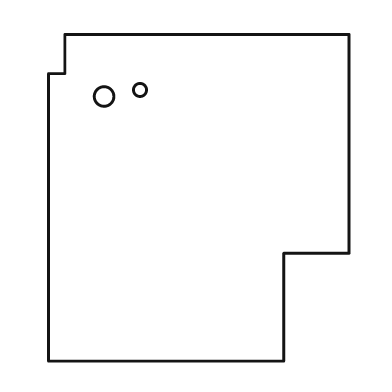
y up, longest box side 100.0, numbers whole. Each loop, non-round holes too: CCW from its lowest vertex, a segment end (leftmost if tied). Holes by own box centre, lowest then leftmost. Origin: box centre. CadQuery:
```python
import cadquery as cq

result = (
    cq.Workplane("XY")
    .moveTo(-46.0, -50.0)
    .lineTo(26.0, -50.0)
    .lineTo(26.0, -17.0)
    .lineTo(46.0, -17.0)
    .lineTo(46.0, 50.0)
    .lineTo(-41.0, 50.0)
    .lineTo(-41.0, 38.0)
    .lineTo(-46.0, 38.0)
    .close()
    .moveTo(-29.0, 31.0)
    .circle(3.0)
    .moveTo(-18.0, 33.0)
    .circle(2.0)
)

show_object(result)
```